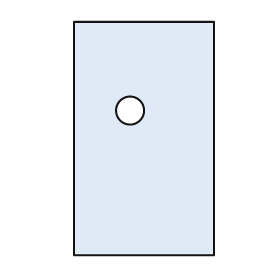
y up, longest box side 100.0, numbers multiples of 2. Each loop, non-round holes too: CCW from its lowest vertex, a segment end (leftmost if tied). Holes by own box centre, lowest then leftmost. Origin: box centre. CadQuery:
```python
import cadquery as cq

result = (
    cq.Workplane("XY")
    .moveTo(-30.0, -50.0)
    .lineTo(30.0, -50.0)
    .lineTo(30.0, 50.0)
    .lineTo(-30.0, 50.0)
    .close()
    .moveTo(-6.0, 12.0)
    .circle(6.0)
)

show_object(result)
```